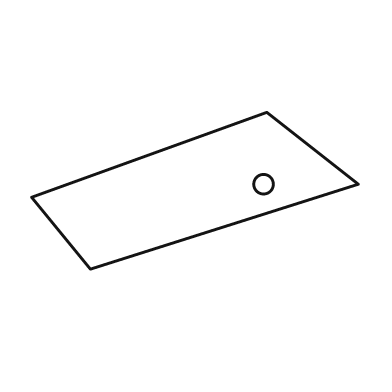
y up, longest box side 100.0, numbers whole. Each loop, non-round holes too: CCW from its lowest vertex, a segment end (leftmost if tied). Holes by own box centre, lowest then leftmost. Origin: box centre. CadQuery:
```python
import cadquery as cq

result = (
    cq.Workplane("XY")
    .moveTo(-32.0, -24.0)
    .lineTo(50.0, 2.0)
    .lineTo(22.0, 24.0)
    .lineTo(-50.0, -2.0)
    .close()
    .moveTo(21.0, 2.0)
    .circle(3.0)
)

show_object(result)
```